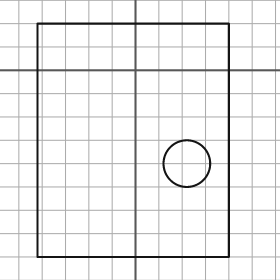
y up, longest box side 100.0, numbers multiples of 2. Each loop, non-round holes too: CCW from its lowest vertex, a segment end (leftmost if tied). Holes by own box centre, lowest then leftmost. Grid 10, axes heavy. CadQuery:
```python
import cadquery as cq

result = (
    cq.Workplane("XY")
    .moveTo(-42.0, -80.0)
    .lineTo(40.0, -80.0)
    .lineTo(40.0, 20.0)
    .lineTo(-42.0, 20.0)
    .close()
    .moveTo(22.0, -40.0)
    .circle(10.0)
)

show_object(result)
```